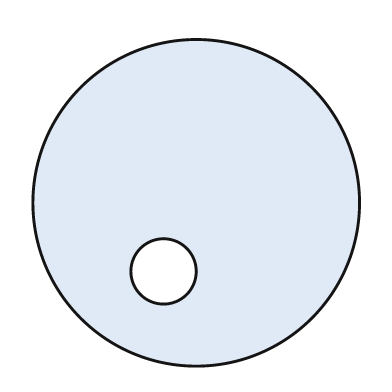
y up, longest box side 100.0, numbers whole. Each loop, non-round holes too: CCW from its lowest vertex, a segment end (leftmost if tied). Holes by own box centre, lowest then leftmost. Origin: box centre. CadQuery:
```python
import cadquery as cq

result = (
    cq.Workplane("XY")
    .moveTo(0.0, 0.0)
    .circle(50.0)
    .moveTo(-10.0, -21.0)
    .circle(10.0)
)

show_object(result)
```